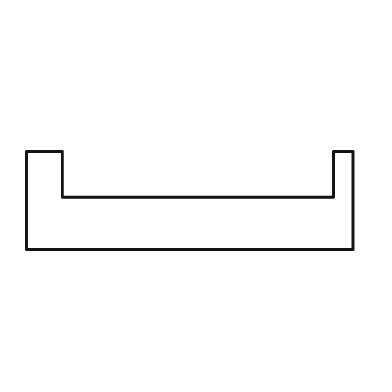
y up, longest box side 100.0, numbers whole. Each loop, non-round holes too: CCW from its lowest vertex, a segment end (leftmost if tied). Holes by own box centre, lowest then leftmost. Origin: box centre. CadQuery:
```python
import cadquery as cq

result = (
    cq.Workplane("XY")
    .moveTo(-50.0, -15.0)
    .lineTo(50.0, -15.0)
    .lineTo(50.0, 15.0)
    .lineTo(44.0, 15.0)
    .lineTo(44.0, 1.0)
    .lineTo(-39.0, 1.0)
    .lineTo(-39.0, 15.0)
    .lineTo(-50.0, 15.0)
    .close()
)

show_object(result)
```